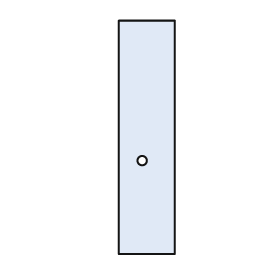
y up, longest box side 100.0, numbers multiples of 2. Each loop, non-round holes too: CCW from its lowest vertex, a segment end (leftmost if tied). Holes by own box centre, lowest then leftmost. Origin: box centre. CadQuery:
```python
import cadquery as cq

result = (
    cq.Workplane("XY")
    .moveTo(-12.0, -50.0)
    .lineTo(12.0, -50.0)
    .lineTo(12.0, 50.0)
    .lineTo(-12.0, 50.0)
    .close()
    .moveTo(-2.0, -10.0)
    .circle(2.0)
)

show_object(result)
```